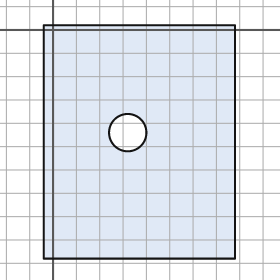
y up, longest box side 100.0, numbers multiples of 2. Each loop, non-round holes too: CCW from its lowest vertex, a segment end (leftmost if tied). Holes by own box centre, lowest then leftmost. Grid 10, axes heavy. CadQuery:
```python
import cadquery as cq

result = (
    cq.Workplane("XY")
    .moveTo(-4.0, -98.0)
    .lineTo(78.0, -98.0)
    .lineTo(78.0, 2.0)
    .lineTo(-4.0, 2.0)
    .close()
    .moveTo(32.0, -44.0)
    .circle(8.0)
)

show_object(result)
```